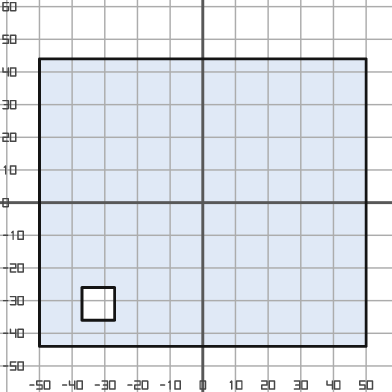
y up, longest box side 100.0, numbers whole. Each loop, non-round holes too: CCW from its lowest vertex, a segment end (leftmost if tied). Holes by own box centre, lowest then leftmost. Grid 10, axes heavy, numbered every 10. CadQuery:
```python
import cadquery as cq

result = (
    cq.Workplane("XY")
    .moveTo(-50.0, -44.0)
    .lineTo(50.0, -44.0)
    .lineTo(50.0, 44.0)
    .lineTo(-50.0, 44.0)
    .close()
    .moveTo(-37.0, -36.0)
    .lineTo(-27.0, -36.0)
    .lineTo(-27.0, -26.0)
    .lineTo(-37.0, -26.0)
    .close()
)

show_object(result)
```